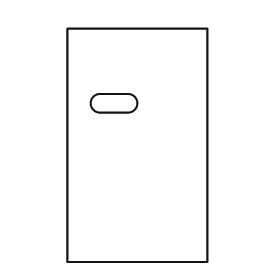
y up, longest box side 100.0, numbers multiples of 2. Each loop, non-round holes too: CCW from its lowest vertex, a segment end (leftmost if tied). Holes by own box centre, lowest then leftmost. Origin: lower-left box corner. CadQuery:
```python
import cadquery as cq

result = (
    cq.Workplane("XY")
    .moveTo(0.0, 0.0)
    .lineTo(60.0, 0.0)
    .lineTo(60.0, 100.0)
    .lineTo(0.0, 100.0)
    .close()
    .moveTo(14.0, 64.0)
    .lineTo(26.0, 64.0)
    .threePointArc((30.0, 68.0), (26.0, 72.0))
    .lineTo(14.0, 72.0)
    .threePointArc((10.0, 68.0), (14.0, 64.0))
    .close()
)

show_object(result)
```